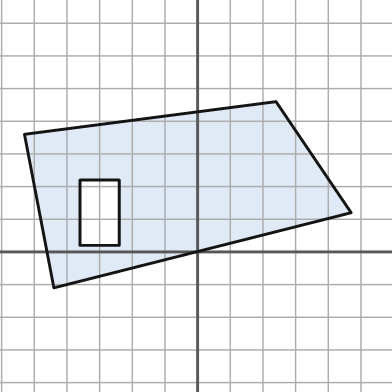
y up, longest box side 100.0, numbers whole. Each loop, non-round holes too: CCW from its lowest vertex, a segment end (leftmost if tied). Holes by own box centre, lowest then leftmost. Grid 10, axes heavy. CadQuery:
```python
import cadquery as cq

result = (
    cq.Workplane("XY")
    .moveTo(-44.0, -11.0)
    .lineTo(47.0, 12.0)
    .lineTo(24.0, 46.0)
    .lineTo(-53.0, 36.0)
    .close()
    .moveTo(-36.0, 2.0)
    .lineTo(-24.0, 2.0)
    .lineTo(-24.0, 22.0)
    .lineTo(-36.0, 22.0)
    .close()
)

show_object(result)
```